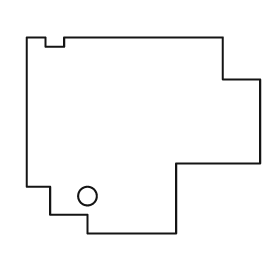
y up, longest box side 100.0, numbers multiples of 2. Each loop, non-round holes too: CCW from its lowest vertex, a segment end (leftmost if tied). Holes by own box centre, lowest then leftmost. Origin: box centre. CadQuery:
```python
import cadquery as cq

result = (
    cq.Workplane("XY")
    .moveTo(-24.0, -42.0)
    .lineTo(14.0, -42.0)
    .lineTo(14.0, -12.0)
    .lineTo(50.0, -12.0)
    .lineTo(50.0, 24.0)
    .lineTo(34.0, 24.0)
    .lineTo(34.0, 42.0)
    .lineTo(-34.0, 42.0)
    .lineTo(-34.0, 38.0)
    .lineTo(-42.0, 38.0)
    .lineTo(-42.0, 42.0)
    .lineTo(-50.0, 42.0)
    .lineTo(-50.0, -22.0)
    .lineTo(-40.0, -22.0)
    .lineTo(-40.0, -34.0)
    .lineTo(-24.0, -34.0)
    .close()
    .moveTo(-24.0, -26.0)
    .circle(4.0)
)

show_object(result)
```